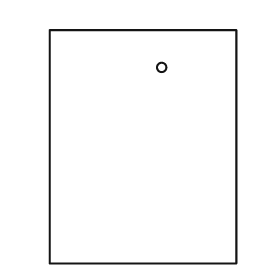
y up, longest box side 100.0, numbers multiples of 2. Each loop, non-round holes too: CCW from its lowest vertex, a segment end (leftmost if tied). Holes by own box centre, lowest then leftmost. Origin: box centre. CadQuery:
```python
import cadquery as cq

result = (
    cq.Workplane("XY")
    .moveTo(-40.0, -50.0)
    .lineTo(40.0, -50.0)
    .lineTo(40.0, 50.0)
    .lineTo(-40.0, 50.0)
    .close()
    .moveTo(8.0, 34.0)
    .circle(2.0)
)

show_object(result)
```